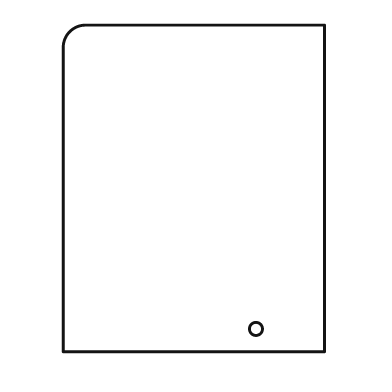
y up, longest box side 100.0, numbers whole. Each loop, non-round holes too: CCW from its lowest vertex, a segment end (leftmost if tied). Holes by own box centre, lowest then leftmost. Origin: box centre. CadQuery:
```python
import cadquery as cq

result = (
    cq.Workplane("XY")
    .moveTo(-40.0, -50.0)
    .lineTo(40.0, -50.0)
    .lineTo(40.0, 50.0)
    .lineTo(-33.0, 50.0)
    .threePointArc((-38.0, 48.0), (-40.0, 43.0))
    .close()
    .moveTo(19.0, -43.0)
    .circle(2.0)
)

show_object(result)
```